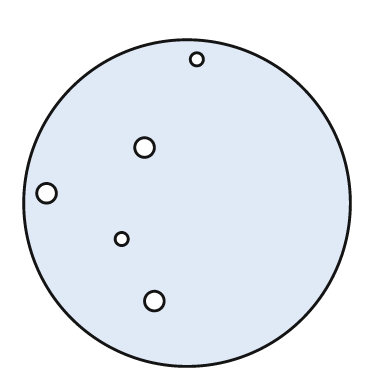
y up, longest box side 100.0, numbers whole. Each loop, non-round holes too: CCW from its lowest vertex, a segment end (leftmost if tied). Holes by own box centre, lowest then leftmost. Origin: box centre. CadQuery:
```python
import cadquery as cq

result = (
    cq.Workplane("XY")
    .moveTo(0.0, 0.0)
    .circle(50.0)
    .moveTo(-10.0, -30.0)
    .circle(3.0)
    .moveTo(-20.0, -11.0)
    .circle(2.0)
    .moveTo(-43.0, 3.0)
    .circle(3.0)
    .moveTo(-13.0, 17.0)
    .circle(3.0)
    .moveTo(3.0, 44.0)
    .circle(2.0)
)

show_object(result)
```